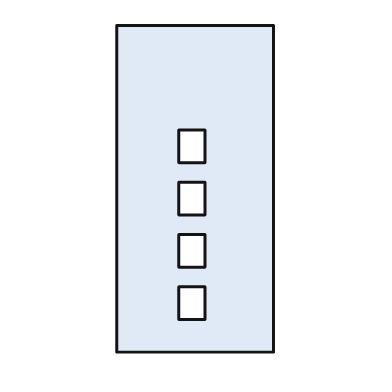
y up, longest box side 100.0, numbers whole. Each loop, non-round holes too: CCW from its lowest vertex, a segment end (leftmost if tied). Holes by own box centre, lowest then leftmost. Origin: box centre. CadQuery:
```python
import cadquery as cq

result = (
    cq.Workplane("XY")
    .moveTo(-24.0, -50.0)
    .lineTo(24.0, -50.0)
    .lineTo(24.0, 50.0)
    .lineTo(-24.0, 50.0)
    .close()
    .moveTo(-5.0, -40.0)
    .lineTo(3.0, -40.0)
    .lineTo(3.0, -30.0)
    .lineTo(-5.0, -30.0)
    .close()
    .moveTo(-5.0, -24.0)
    .lineTo(3.0, -24.0)
    .lineTo(3.0, -14.0)
    .lineTo(-5.0, -14.0)
    .close()
    .moveTo(-5.0, -8.0)
    .lineTo(3.0, -8.0)
    .lineTo(3.0, 2.0)
    .lineTo(-5.0, 2.0)
    .close()
    .moveTo(-5.0, 8.0)
    .lineTo(3.0, 8.0)
    .lineTo(3.0, 18.0)
    .lineTo(-5.0, 18.0)
    .close()
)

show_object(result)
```